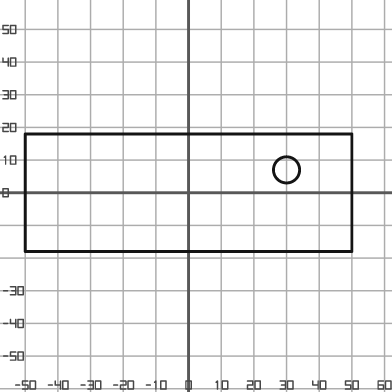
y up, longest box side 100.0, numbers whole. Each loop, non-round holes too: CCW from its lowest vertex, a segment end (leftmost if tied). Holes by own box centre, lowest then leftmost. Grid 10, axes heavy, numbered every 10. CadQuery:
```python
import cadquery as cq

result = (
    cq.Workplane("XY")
    .moveTo(-50.0, -18.0)
    .lineTo(50.0, -18.0)
    .lineTo(50.0, 18.0)
    .lineTo(-50.0, 18.0)
    .close()
    .moveTo(30.0, 7.0)
    .circle(4.0)
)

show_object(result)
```